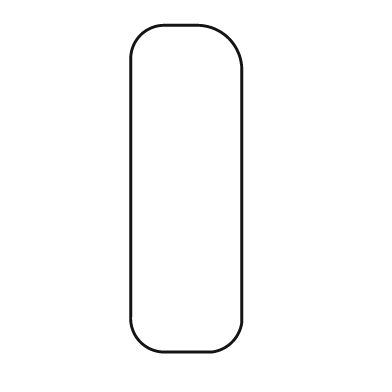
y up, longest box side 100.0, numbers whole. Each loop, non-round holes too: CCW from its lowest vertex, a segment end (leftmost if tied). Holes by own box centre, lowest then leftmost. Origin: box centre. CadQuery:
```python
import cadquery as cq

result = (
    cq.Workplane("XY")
    .moveTo(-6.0, -50.0)
    .lineTo(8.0, -50.0)
    .threePointArc((14.0, -47.0), (17.0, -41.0))
    .lineTo(17.0, 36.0)
    .threePointArc((13.0, 46.0), (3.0, 50.0))
    .lineTo(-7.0, 50.0)
    .threePointArc((-14.0, 47.0), (-17.0, 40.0))
    .lineTo(-17.0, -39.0)
    .threePointArc((-14.0, -47.0), (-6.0, -50.0))
    .close()
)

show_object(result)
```